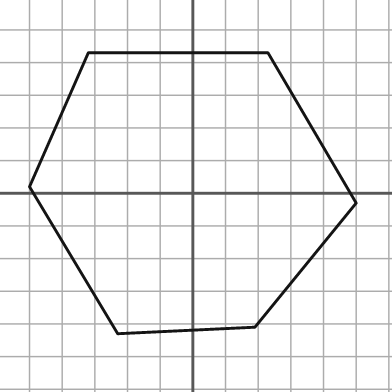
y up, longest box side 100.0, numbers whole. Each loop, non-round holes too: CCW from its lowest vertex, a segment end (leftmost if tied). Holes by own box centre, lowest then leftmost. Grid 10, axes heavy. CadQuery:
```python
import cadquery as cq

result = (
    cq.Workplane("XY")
    .moveTo(-23.0, -43.0)
    .lineTo(19.0, -41.0)
    .lineTo(50.0, -3.0)
    .lineTo(23.0, 43.0)
    .lineTo(-32.0, 43.0)
    .lineTo(-50.0, 2.0)
    .close()
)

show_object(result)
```